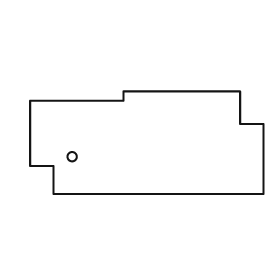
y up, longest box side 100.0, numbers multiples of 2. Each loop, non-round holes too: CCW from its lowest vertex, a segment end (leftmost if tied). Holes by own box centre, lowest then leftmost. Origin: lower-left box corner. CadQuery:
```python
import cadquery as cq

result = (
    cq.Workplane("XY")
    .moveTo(10.0, 0.0)
    .lineTo(100.0, 0.0)
    .lineTo(100.0, 30.0)
    .lineTo(90.0, 30.0)
    .lineTo(90.0, 44.0)
    .lineTo(40.0, 44.0)
    .lineTo(40.0, 40.0)
    .lineTo(0.0, 40.0)
    .lineTo(0.0, 12.0)
    .lineTo(10.0, 12.0)
    .close()
    .moveTo(18.0, 16.0)
    .circle(2.0)
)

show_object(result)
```